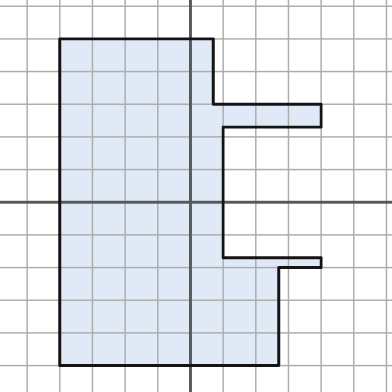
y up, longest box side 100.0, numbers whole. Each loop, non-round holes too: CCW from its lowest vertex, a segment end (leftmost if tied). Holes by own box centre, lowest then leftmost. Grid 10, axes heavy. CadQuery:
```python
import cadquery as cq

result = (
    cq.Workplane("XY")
    .moveTo(-40.0, -50.0)
    .lineTo(27.0, -50.0)
    .lineTo(27.0, -20.0)
    .lineTo(40.0, -20.0)
    .lineTo(40.0, -17.0)
    .lineTo(10.0, -17.0)
    .lineTo(10.0, 23.0)
    .lineTo(40.0, 23.0)
    .lineTo(40.0, 30.0)
    .lineTo(7.0, 30.0)
    .lineTo(7.0, 50.0)
    .lineTo(-40.0, 50.0)
    .close()
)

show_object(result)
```